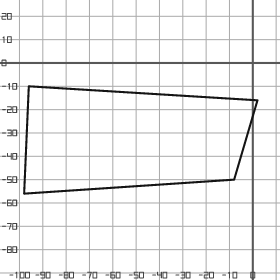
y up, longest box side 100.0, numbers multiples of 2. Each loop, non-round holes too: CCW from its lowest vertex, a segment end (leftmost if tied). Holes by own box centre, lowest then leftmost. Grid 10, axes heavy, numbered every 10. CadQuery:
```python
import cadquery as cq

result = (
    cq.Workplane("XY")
    .moveTo(-98.0, -56.0)
    .lineTo(-8.0, -50.0)
    .lineTo(2.0, -16.0)
    .lineTo(-96.0, -10.0)
    .close()
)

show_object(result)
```